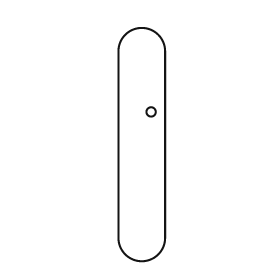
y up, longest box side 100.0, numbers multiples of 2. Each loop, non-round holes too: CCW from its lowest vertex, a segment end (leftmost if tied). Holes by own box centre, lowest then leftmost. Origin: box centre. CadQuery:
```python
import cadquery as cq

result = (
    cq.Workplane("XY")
    .moveTo(-10.0, -40.0)
    .threePointArc((0.0, -50.0), (10.0, -40.0))
    .lineTo(10.0, 40.0)
    .threePointArc((0.0, 50.0), (-10.0, 40.0))
    .close()
    .moveTo(4.0, 14.0)
    .circle(2.0)
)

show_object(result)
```